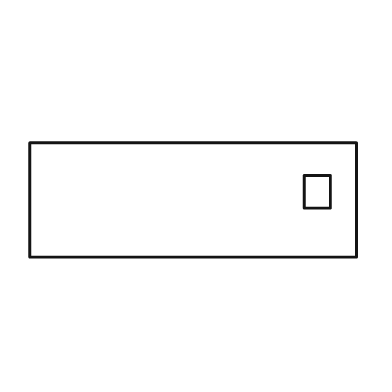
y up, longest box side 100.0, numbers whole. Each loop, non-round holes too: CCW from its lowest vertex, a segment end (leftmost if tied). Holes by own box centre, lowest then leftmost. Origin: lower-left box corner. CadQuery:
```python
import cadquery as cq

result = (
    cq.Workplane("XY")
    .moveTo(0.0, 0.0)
    .lineTo(100.0, 0.0)
    .lineTo(100.0, 35.0)
    .lineTo(0.0, 35.0)
    .close()
    .moveTo(84.0, 15.0)
    .lineTo(92.0, 15.0)
    .lineTo(92.0, 25.0)
    .lineTo(84.0, 25.0)
    .close()
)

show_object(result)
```